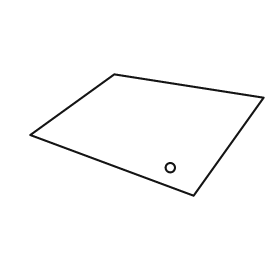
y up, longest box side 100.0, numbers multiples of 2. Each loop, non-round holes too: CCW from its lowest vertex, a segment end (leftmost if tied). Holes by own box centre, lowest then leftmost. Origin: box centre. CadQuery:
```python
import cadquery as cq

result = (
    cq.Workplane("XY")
    .moveTo(20.0, -26.0)
    .lineTo(50.0, 16.0)
    .lineTo(-14.0, 26.0)
    .lineTo(-50.0, 0.0)
    .close()
    .moveTo(10.0, -14.0)
    .circle(2.0)
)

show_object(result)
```